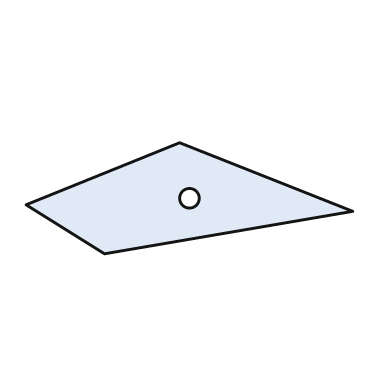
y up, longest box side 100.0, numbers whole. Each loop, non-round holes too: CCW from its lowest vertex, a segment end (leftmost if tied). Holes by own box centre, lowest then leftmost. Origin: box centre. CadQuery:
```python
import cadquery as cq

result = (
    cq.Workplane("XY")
    .moveTo(-26.0, -17.0)
    .lineTo(50.0, -4.0)
    .lineTo(-3.0, 17.0)
    .lineTo(-50.0, -2.0)
    .close()
    .moveTo(0.0, 0.0)
    .circle(3.0)
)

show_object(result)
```